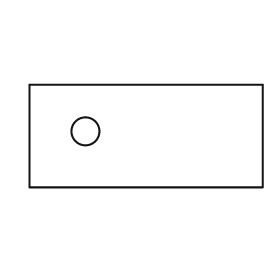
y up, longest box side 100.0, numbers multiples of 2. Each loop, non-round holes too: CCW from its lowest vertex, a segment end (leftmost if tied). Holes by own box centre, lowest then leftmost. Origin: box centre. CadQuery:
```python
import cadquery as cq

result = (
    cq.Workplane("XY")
    .moveTo(-50.0, -22.0)
    .lineTo(50.0, -22.0)
    .lineTo(50.0, 22.0)
    .lineTo(-50.0, 22.0)
    .close()
    .moveTo(-26.0, 2.0)
    .circle(6.0)
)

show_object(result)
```